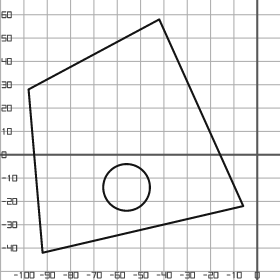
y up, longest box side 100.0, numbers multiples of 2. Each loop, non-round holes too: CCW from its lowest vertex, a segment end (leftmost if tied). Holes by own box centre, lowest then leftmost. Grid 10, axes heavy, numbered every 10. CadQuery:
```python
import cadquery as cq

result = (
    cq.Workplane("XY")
    .moveTo(-92.0, -42.0)
    .lineTo(-6.0, -22.0)
    .lineTo(-42.0, 58.0)
    .lineTo(-98.0, 28.0)
    .close()
    .moveTo(-56.0, -14.0)
    .circle(10.0)
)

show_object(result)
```